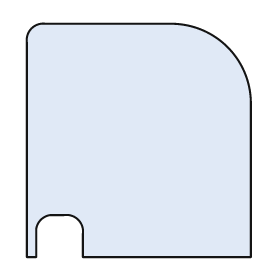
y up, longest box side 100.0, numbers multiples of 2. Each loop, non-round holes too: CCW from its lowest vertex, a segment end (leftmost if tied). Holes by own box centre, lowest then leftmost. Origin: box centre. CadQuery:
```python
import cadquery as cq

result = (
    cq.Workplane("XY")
    .moveTo(-48.0, -50.0)
    .lineTo(-44.0, -50.0)
    .lineTo(-44.0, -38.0)
    .threePointArc((-42.0, -34.0), (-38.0, -32.0))
    .lineTo(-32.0, -32.0)
    .threePointArc((-26.0, -34.0), (-24.0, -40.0))
    .lineTo(-24.0, -50.0)
    .lineTo(48.0, -50.0)
    .lineTo(48.0, 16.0)
    .threePointArc((38.0, 40.0), (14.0, 50.0))
    .lineTo(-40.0, 50.0)
    .threePointArc((-46.0, 48.0), (-48.0, 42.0))
    .close()
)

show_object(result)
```